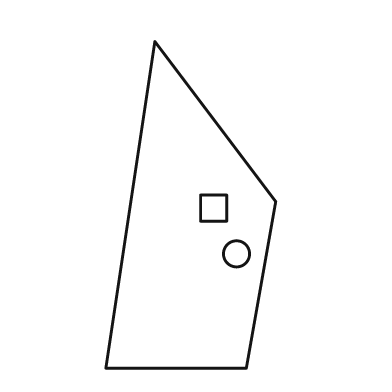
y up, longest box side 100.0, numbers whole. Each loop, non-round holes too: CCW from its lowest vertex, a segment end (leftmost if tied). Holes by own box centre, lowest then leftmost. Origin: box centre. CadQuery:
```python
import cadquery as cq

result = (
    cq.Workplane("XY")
    .moveTo(-26.0, -50.0)
    .lineTo(17.0, -50.0)
    .lineTo(26.0, 1.0)
    .lineTo(-11.0, 50.0)
    .close()
    .moveTo(14.0, -15.0)
    .circle(4.0)
    .moveTo(3.0, -5.0)
    .lineTo(11.0, -5.0)
    .lineTo(11.0, 3.0)
    .lineTo(3.0, 3.0)
    .close()
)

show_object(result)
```